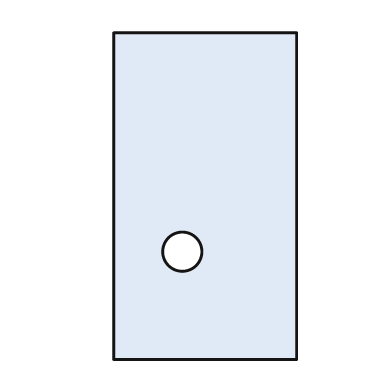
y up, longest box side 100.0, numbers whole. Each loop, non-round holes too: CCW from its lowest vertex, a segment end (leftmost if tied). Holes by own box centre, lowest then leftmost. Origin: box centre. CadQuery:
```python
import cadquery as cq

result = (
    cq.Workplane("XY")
    .moveTo(-28.0, -50.0)
    .lineTo(28.0, -50.0)
    .lineTo(28.0, 50.0)
    .lineTo(-28.0, 50.0)
    .close()
    .moveTo(-7.0, -17.0)
    .circle(6.0)
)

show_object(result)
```